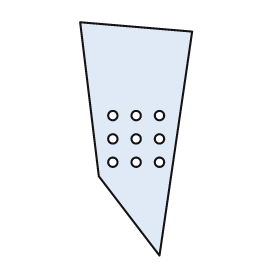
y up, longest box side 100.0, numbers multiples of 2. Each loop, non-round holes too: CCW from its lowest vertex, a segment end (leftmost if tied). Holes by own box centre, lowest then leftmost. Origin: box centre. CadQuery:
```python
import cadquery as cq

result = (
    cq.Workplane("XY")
    .moveTo(10.0, -50.0)
    .lineTo(24.0, 46.0)
    .lineTo(-24.0, 50.0)
    .lineTo(-16.0, -16.0)
    .close()
    .moveTo(-10.0, -10.0)
    .circle(2.0)
    .moveTo(0.0, -10.0)
    .circle(2.0)
    .moveTo(10.0, -10.0)
    .circle(2.0)
    .moveTo(-10.0, 0.0)
    .circle(2.0)
    .moveTo(0.0, 0.0)
    .circle(2.0)
    .moveTo(10.0, 0.0)
    .circle(2.0)
    .moveTo(-10.0, 10.0)
    .circle(2.0)
    .moveTo(0.0, 10.0)
    .circle(2.0)
    .moveTo(10.0, 10.0)
    .circle(2.0)
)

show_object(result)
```